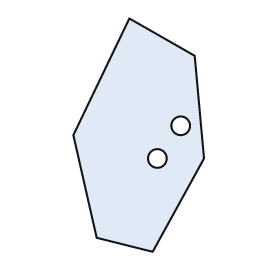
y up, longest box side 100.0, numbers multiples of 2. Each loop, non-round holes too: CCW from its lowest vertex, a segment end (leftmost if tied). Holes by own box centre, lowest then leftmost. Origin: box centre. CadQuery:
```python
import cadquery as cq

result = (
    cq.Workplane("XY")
    .moveTo(6.0, -50.0)
    .lineTo(28.0, -10.0)
    .lineTo(24.0, 34.0)
    .lineTo(-4.0, 50.0)
    .lineTo(-28.0, 0.0)
    .lineTo(-18.0, -44.0)
    .close()
    .moveTo(8.0, -10.0)
    .circle(4.0)
    .moveTo(18.0, 4.0)
    .circle(4.0)
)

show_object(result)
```